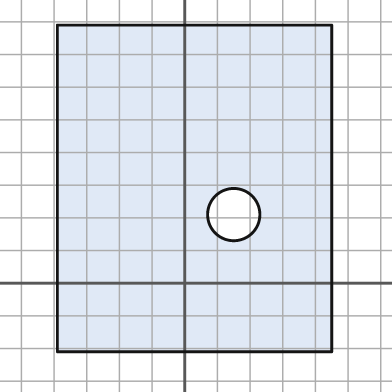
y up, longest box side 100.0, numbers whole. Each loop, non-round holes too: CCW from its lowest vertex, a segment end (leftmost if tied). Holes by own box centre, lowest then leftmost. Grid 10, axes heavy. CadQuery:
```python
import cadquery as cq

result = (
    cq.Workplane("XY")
    .moveTo(-39.0, -21.0)
    .lineTo(45.0, -21.0)
    .lineTo(45.0, 79.0)
    .lineTo(-39.0, 79.0)
    .close()
    .moveTo(15.0, 21.0)
    .circle(8.0)
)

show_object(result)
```